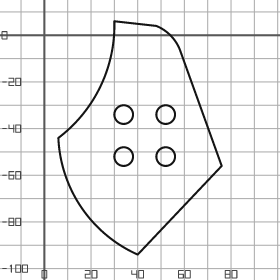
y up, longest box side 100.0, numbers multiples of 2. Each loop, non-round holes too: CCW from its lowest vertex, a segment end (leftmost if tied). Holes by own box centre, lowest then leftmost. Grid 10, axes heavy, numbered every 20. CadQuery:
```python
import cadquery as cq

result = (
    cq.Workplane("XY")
    .moveTo(40.0, -94.0)
    .lineTo(76.0, -56.0)
    .lineTo(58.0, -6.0)
    .threePointArc((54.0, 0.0), (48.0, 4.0))
    .lineTo(30.0, 6.0)
    .threePointArc((24.0, -22.0), (6.0, -44.0))
    .threePointArc((16.0, -74.0), (40.0, -94.0))
    .close()
    .moveTo(34.0, -52.0)
    .circle(4.0)
    .moveTo(52.0, -52.0)
    .circle(4.0)
    .moveTo(34.0, -34.0)
    .circle(4.0)
    .moveTo(52.0, -34.0)
    .circle(4.0)
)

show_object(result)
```